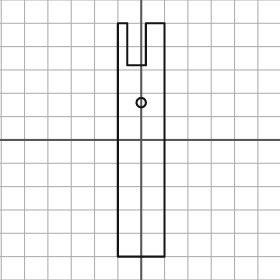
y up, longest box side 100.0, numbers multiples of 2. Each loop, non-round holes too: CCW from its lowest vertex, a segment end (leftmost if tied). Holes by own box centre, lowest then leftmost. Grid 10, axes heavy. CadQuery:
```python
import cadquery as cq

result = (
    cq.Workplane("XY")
    .moveTo(-10.0, -50.0)
    .lineTo(10.0, -50.0)
    .lineTo(10.0, 50.0)
    .lineTo(2.0, 50.0)
    .lineTo(2.0, 32.0)
    .lineTo(-6.0, 32.0)
    .lineTo(-6.0, 50.0)
    .lineTo(-10.0, 50.0)
    .close()
    .moveTo(0.0, 16.0)
    .circle(2.0)
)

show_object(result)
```